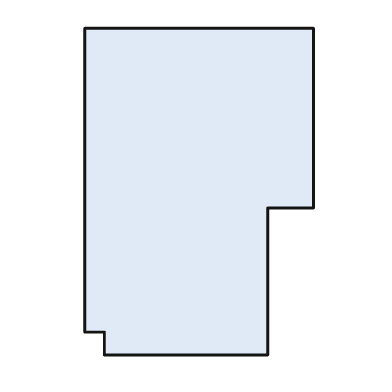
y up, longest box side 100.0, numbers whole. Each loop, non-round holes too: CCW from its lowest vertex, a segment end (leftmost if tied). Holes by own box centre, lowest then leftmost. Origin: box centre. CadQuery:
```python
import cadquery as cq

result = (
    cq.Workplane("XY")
    .moveTo(-29.0, -50.0)
    .lineTo(21.0, -50.0)
    .lineTo(21.0, -5.0)
    .lineTo(35.0, -5.0)
    .lineTo(35.0, 50.0)
    .lineTo(-35.0, 50.0)
    .lineTo(-35.0, -43.0)
    .lineTo(-29.0, -43.0)
    .close()
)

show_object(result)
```